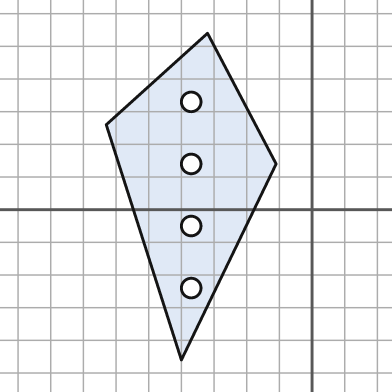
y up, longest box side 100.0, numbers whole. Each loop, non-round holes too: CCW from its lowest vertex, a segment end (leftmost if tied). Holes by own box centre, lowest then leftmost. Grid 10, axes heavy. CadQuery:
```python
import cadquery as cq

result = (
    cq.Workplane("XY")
    .moveTo(-40.0, -46.0)
    .lineTo(-11.0, 14.0)
    .lineTo(-32.0, 54.0)
    .lineTo(-63.0, 26.0)
    .close()
    .moveTo(-37.0, -24.0)
    .circle(3.0)
    .moveTo(-37.0, -5.0)
    .circle(3.0)
    .moveTo(-37.0, 14.0)
    .circle(3.0)
    .moveTo(-37.0, 33.0)
    .circle(3.0)
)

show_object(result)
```